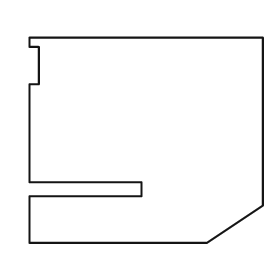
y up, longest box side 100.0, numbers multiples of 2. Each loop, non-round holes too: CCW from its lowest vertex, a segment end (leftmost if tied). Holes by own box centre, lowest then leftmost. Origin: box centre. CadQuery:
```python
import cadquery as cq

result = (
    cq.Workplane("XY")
    .moveTo(-50.0, -44.0)
    .lineTo(26.0, -44.0)
    .lineTo(50.0, -28.0)
    .lineTo(50.0, 44.0)
    .lineTo(-50.0, 44.0)
    .lineTo(-50.0, 40.0)
    .lineTo(-46.0, 40.0)
    .lineTo(-46.0, 24.0)
    .lineTo(-50.0, 24.0)
    .lineTo(-50.0, -18.0)
    .lineTo(-2.0, -18.0)
    .lineTo(-2.0, -24.0)
    .lineTo(-50.0, -24.0)
    .close()
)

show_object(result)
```